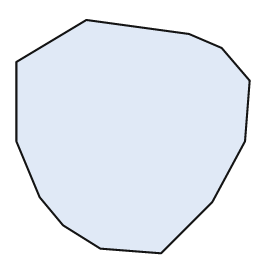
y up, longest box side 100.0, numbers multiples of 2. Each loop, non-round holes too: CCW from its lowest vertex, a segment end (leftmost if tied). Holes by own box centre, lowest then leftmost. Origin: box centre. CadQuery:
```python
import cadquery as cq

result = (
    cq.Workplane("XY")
    .moveTo(12.0, -50.0)
    .lineTo(34.0, -28.0)
    .lineTo(48.0, -2.0)
    .lineTo(50.0, 24.0)
    .lineTo(38.0, 38.0)
    .lineTo(24.0, 44.0)
    .lineTo(-20.0, 50.0)
    .lineTo(-50.0, 32.0)
    .lineTo(-50.0, -2.0)
    .lineTo(-40.0, -26.0)
    .lineTo(-30.0, -38.0)
    .lineTo(-14.0, -48.0)
    .close()
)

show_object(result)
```